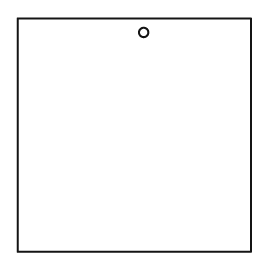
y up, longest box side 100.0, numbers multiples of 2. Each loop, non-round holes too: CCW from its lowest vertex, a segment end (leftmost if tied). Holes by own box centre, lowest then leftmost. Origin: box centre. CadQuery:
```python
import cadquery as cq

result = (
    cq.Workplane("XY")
    .moveTo(-50.0, -50.0)
    .lineTo(50.0, -50.0)
    .lineTo(50.0, 50.0)
    .lineTo(-50.0, 50.0)
    .close()
    .moveTo(4.0, 44.0)
    .circle(2.0)
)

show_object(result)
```